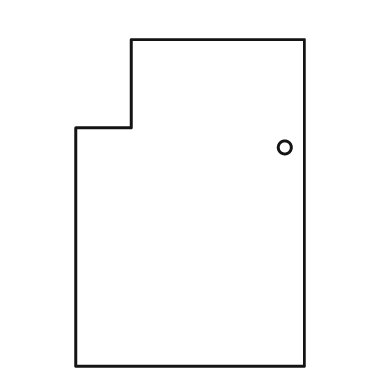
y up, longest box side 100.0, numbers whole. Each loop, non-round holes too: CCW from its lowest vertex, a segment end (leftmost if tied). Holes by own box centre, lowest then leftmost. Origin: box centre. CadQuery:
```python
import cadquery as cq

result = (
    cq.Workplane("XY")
    .moveTo(-35.0, -50.0)
    .lineTo(35.0, -50.0)
    .lineTo(35.0, 50.0)
    .lineTo(-18.0, 50.0)
    .lineTo(-18.0, 23.0)
    .lineTo(-35.0, 23.0)
    .close()
    .moveTo(29.0, 17.0)
    .circle(2.0)
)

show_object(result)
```